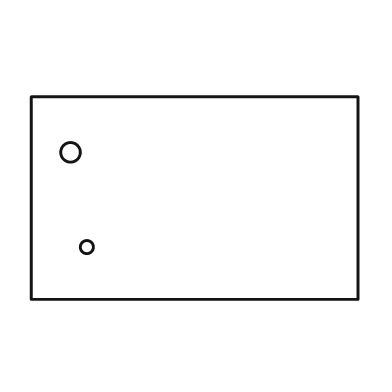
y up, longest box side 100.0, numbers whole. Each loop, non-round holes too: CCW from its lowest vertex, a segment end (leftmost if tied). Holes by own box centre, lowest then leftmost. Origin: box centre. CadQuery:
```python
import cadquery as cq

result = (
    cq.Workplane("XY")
    .moveTo(-50.0, -31.0)
    .lineTo(50.0, -31.0)
    .lineTo(50.0, 31.0)
    .lineTo(-50.0, 31.0)
    .close()
    .moveTo(-33.0, -15.0)
    .circle(2.0)
    .moveTo(-38.0, 14.0)
    .circle(3.0)
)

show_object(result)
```